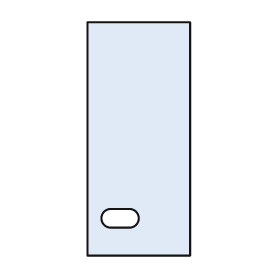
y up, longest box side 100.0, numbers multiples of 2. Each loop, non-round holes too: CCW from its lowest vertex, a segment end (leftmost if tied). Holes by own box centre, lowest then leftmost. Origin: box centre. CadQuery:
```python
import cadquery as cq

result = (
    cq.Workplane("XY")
    .moveTo(-22.0, -50.0)
    .lineTo(22.0, -50.0)
    .lineTo(22.0, 50.0)
    .lineTo(-22.0, 50.0)
    .close()
    .moveTo(-12.0, -38.0)
    .lineTo(-4.0, -38.0)
    .threePointArc((0.0, -34.0), (-4.0, -30.0))
    .lineTo(-12.0, -30.0)
    .threePointArc((-16.0, -34.0), (-12.0, -38.0))
    .close()
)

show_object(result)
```